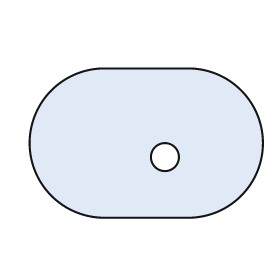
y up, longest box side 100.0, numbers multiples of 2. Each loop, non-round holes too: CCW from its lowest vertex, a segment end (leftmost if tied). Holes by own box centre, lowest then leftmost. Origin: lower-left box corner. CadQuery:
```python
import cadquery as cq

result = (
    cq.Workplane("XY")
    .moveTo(32.0, 0.0)
    .lineTo(68.0, 0.0)
    .threePointArc((100.0, 32.0), (68.0, 64.0))
    .lineTo(32.0, 64.0)
    .threePointArc((0.0, 32.0), (32.0, 0.0))
    .close()
    .moveTo(58.0, 26.0)
    .circle(6.0)
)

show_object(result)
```